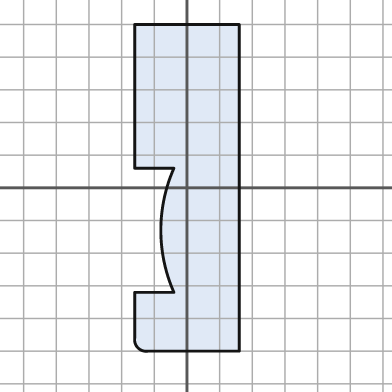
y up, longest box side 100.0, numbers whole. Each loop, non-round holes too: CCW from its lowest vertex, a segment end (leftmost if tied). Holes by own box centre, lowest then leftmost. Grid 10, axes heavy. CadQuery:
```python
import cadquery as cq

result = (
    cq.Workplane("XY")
    .moveTo(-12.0, -50.0)
    .lineTo(16.0, -50.0)
    .lineTo(16.0, 50.0)
    .lineTo(-16.0, 50.0)
    .lineTo(-16.0, 6.0)
    .lineTo(-4.0, 6.0)
    .threePointArc((-8.0, -13.0), (-4.0, -32.0))
    .lineTo(-16.0, -32.0)
    .lineTo(-16.0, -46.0)
    .threePointArc((-15.0, -49.0), (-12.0, -50.0))
    .close()
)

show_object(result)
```